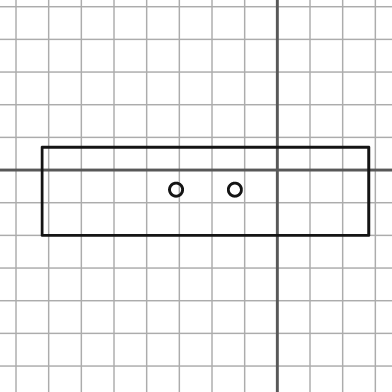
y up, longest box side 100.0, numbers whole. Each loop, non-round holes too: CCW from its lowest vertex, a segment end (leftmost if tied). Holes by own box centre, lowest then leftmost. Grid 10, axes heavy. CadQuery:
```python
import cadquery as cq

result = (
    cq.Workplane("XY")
    .moveTo(-72.0, -20.0)
    .lineTo(28.0, -20.0)
    .lineTo(28.0, 7.0)
    .lineTo(-72.0, 7.0)
    .close()
    .moveTo(-31.0, -6.0)
    .circle(2.0)
    .moveTo(-13.0, -6.0)
    .circle(2.0)
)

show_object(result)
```